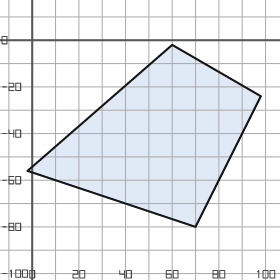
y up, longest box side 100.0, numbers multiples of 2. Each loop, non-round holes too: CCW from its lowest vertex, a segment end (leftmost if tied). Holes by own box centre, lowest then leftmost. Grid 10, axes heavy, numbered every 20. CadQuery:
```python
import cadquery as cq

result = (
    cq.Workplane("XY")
    .moveTo(70.0, -80.0)
    .lineTo(98.0, -24.0)
    .lineTo(60.0, -2.0)
    .lineTo(-2.0, -56.0)
    .close()
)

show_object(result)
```